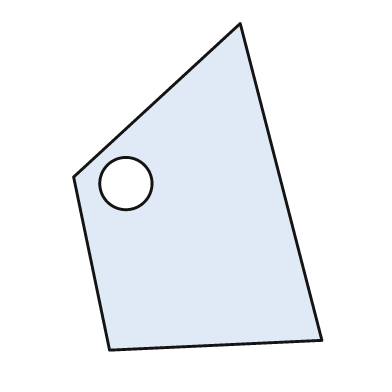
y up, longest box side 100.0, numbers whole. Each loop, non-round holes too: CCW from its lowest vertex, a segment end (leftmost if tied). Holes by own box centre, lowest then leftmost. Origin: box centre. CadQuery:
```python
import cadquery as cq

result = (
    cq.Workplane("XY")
    .moveTo(-27.0, -50.0)
    .lineTo(38.0, -47.0)
    .lineTo(13.0, 50.0)
    .lineTo(-38.0, 3.0)
    .close()
    .moveTo(-22.0, 1.0)
    .circle(8.0)
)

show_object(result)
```